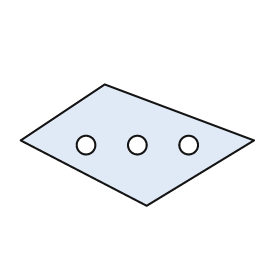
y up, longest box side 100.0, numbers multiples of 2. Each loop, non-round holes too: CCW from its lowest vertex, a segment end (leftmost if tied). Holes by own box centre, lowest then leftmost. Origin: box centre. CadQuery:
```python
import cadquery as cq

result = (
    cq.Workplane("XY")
    .moveTo(4.0, -26.0)
    .lineTo(50.0, 2.0)
    .lineTo(-14.0, 26.0)
    .lineTo(-50.0, 2.0)
    .close()
    .moveTo(-22.0, 0.0)
    .circle(4.0)
    .moveTo(0.0, 0.0)
    .circle(4.0)
    .moveTo(22.0, 0.0)
    .circle(4.0)
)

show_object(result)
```